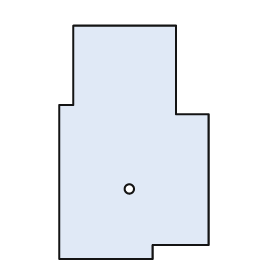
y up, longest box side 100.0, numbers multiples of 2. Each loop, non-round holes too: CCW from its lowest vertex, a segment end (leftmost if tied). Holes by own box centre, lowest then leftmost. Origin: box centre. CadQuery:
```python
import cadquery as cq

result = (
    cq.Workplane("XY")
    .moveTo(-32.0, -50.0)
    .lineTo(8.0, -50.0)
    .lineTo(8.0, -44.0)
    .lineTo(32.0, -44.0)
    .lineTo(32.0, 12.0)
    .lineTo(18.0, 12.0)
    .lineTo(18.0, 50.0)
    .lineTo(-26.0, 50.0)
    .lineTo(-26.0, 16.0)
    .lineTo(-32.0, 16.0)
    .close()
    .moveTo(-2.0, -20.0)
    .circle(2.0)
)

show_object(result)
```